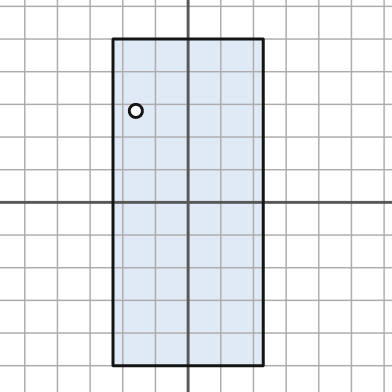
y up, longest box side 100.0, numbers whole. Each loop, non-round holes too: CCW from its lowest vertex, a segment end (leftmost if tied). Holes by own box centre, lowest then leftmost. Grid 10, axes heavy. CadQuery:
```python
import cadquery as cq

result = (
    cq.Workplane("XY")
    .moveTo(-23.0, -50.0)
    .lineTo(23.0, -50.0)
    .lineTo(23.0, 50.0)
    .lineTo(-23.0, 50.0)
    .close()
    .moveTo(-16.0, 28.0)
    .circle(2.0)
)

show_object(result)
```